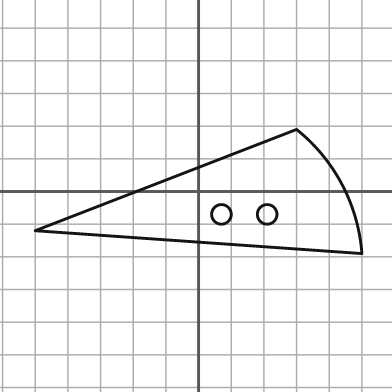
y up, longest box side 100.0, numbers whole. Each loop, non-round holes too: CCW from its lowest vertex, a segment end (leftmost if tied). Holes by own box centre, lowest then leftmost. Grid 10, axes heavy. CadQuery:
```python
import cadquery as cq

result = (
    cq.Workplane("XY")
    .moveTo(50.0, -19.0)
    .threePointArc((44.0, 2.0), (30.0, 19.0))
    .lineTo(-50.0, -12.0)
    .close()
    .moveTo(7.0, -7.0)
    .circle(3.0)
    .moveTo(21.0, -7.0)
    .circle(3.0)
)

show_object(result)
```